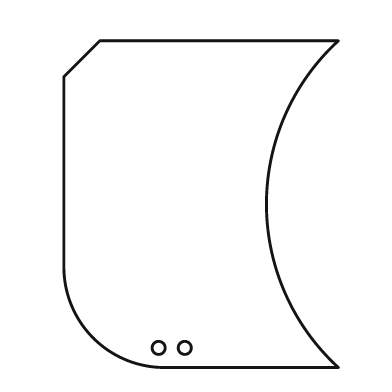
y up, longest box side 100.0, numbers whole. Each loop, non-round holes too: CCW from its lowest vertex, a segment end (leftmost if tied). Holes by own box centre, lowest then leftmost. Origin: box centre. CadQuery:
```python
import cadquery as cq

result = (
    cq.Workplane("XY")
    .moveTo(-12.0, -50.0)
    .lineTo(42.0, -50.0)
    .threePointArc((20.0, 0.0), (42.0, 50.0))
    .lineTo(-31.0, 50.0)
    .lineTo(-42.0, 39.0)
    .lineTo(-42.0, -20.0)
    .threePointArc((-33.0, -41.0), (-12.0, -50.0))
    .close()
    .moveTo(-13.0, -44.0)
    .circle(2.0)
    .moveTo(-5.0, -44.0)
    .circle(2.0)
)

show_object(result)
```